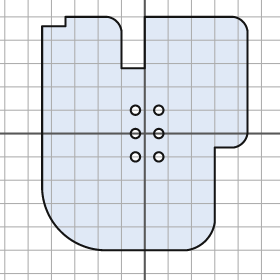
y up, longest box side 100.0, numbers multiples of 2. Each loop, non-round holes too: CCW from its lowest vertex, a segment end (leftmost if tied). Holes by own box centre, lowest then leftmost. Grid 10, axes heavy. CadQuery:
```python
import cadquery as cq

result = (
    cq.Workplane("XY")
    .moveTo(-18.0, -50.0)
    .lineTo(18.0, -50.0)
    .threePointArc((26.0, -46.0), (30.0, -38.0))
    .lineTo(30.0, -6.0)
    .lineTo(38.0, -6.0)
    .threePointArc((42.0, -4.0), (44.0, 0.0))
    .lineTo(44.0, 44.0)
    .threePointArc((42.0, 48.0), (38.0, 50.0))
    .lineTo(0.0, 50.0)
    .lineTo(0.0, 28.0)
    .lineTo(-10.0, 28.0)
    .lineTo(-10.0, 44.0)
    .threePointArc((-12.0, 48.0), (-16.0, 50.0))
    .lineTo(-34.0, 50.0)
    .lineTo(-34.0, 46.0)
    .lineTo(-44.0, 46.0)
    .lineTo(-44.0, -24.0)
    .threePointArc((-36.0, -42.0), (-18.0, -50.0))
    .close()
    .moveTo(-4.0, -10.0)
    .circle(2.0)
    .moveTo(6.0, -10.0)
    .circle(2.0)
    .moveTo(-4.0, 0.0)
    .circle(2.0)
    .moveTo(6.0, 0.0)
    .circle(2.0)
    .moveTo(-4.0, 10.0)
    .circle(2.0)
    .moveTo(6.0, 10.0)
    .circle(2.0)
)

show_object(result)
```